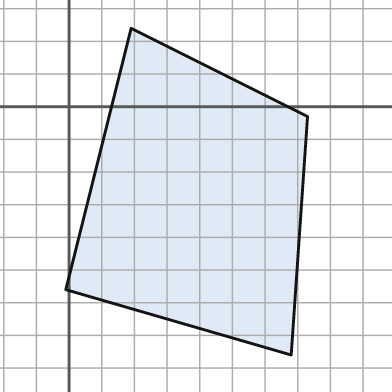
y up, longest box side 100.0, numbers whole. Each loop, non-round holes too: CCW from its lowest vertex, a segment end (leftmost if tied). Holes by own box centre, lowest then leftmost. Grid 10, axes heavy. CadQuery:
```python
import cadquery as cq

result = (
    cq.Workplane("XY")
    .moveTo(68.0, -76.0)
    .lineTo(73.0, -3.0)
    .lineTo(19.0, 24.0)
    .lineTo(-1.0, -56.0)
    .close()
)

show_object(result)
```